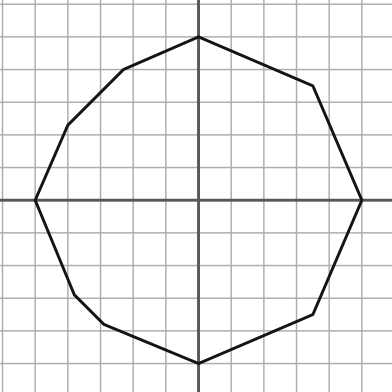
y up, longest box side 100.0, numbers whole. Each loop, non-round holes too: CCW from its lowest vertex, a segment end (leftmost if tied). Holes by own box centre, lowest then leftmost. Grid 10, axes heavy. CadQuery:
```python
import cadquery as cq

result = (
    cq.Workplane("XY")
    .moveTo(0.0, -50.0)
    .lineTo(35.0, -35.0)
    .lineTo(50.0, 0.0)
    .lineTo(35.0, 35.0)
    .lineTo(0.0, 50.0)
    .lineTo(-23.0, 40.0)
    .lineTo(-40.0, 23.0)
    .lineTo(-50.0, 0.0)
    .lineTo(-38.0, -29.0)
    .lineTo(-29.0, -38.0)
    .close()
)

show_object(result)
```